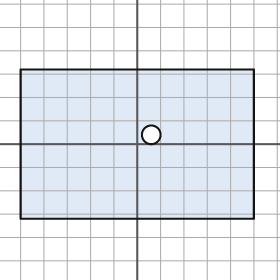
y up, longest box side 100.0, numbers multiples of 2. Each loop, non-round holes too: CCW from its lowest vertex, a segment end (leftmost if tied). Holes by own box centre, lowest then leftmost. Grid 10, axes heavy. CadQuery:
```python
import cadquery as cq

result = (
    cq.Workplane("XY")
    .moveTo(-50.0, -32.0)
    .lineTo(50.0, -32.0)
    .lineTo(50.0, 32.0)
    .lineTo(-50.0, 32.0)
    .close()
    .moveTo(6.0, 4.0)
    .circle(4.0)
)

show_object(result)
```